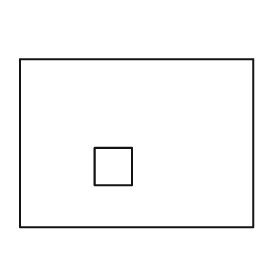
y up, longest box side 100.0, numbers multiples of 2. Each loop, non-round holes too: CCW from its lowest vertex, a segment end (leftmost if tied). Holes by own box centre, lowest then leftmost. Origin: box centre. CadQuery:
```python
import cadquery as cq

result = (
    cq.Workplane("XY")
    .moveTo(-50.0, -36.0)
    .lineTo(50.0, -36.0)
    .lineTo(50.0, 36.0)
    .lineTo(-50.0, 36.0)
    .close()
    .moveTo(-18.0, -18.0)
    .lineTo(-2.0, -18.0)
    .lineTo(-2.0, -2.0)
    .lineTo(-18.0, -2.0)
    .close()
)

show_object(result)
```